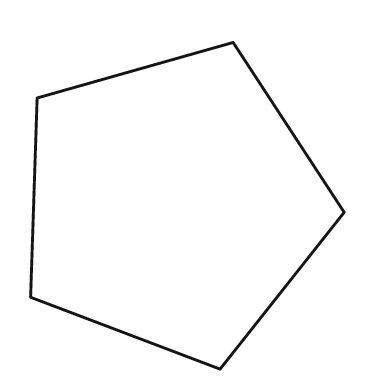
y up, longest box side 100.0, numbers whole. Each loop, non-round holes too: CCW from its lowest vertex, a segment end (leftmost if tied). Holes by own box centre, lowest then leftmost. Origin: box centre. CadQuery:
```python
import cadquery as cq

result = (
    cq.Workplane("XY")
    .moveTo(10.0, -50.0)
    .lineTo(48.0, -2.0)
    .lineTo(14.0, 50.0)
    .lineTo(-46.0, 33.0)
    .lineTo(-48.0, -28.0)
    .close()
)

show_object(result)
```